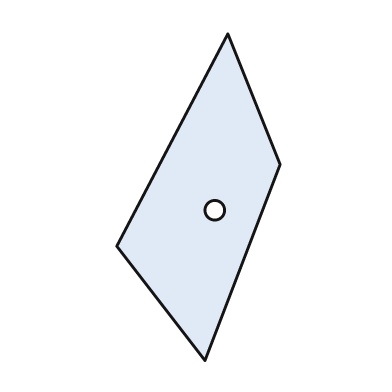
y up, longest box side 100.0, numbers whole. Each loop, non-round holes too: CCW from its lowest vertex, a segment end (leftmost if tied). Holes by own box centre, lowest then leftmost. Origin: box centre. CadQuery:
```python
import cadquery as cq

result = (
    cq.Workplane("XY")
    .moveTo(2.0, -50.0)
    .lineTo(25.0, 10.0)
    .lineTo(9.0, 50.0)
    .lineTo(-25.0, -15.0)
    .close()
    .moveTo(5.0, -4.0)
    .circle(3.0)
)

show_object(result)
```